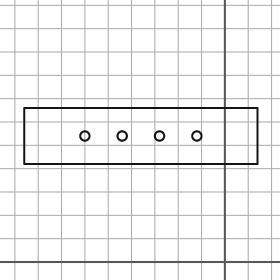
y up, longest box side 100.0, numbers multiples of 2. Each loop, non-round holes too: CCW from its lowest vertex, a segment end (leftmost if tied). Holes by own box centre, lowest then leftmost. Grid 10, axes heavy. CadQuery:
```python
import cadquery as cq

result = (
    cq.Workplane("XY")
    .moveTo(-86.0, 42.0)
    .lineTo(14.0, 42.0)
    .lineTo(14.0, 66.0)
    .lineTo(-86.0, 66.0)
    .close()
    .moveTo(-60.0, 54.0)
    .circle(2.0)
    .moveTo(-44.0, 54.0)
    .circle(2.0)
    .moveTo(-28.0, 54.0)
    .circle(2.0)
    .moveTo(-12.0, 54.0)
    .circle(2.0)
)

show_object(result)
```